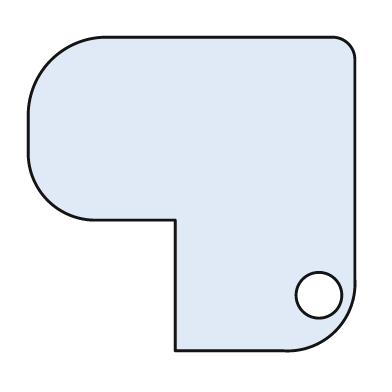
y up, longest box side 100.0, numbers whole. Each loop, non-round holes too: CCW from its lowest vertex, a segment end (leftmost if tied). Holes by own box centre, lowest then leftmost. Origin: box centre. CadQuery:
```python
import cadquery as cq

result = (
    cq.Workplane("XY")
    .moveTo(-5.0, -48.0)
    .lineTo(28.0, -48.0)
    .threePointArc((44.0, -42.0), (50.0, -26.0))
    .lineTo(50.0, 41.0)
    .threePointArc((48.0, 46.0), (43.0, 48.0))
    .lineTo(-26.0, 48.0)
    .threePointArc((-43.0, 41.0), (-50.0, 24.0))
    .lineTo(-50.0, 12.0)
    .threePointArc((-44.0, -2.0), (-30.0, -8.0))
    .lineTo(-5.0, -8.0)
    .close()
    .moveTo(39.0, -31.0)
    .circle(7.0)
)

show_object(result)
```